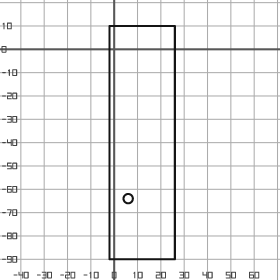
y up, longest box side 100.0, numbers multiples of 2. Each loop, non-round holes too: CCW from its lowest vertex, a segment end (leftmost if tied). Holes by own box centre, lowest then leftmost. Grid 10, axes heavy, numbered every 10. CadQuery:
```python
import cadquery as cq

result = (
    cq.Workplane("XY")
    .moveTo(-2.0, -90.0)
    .lineTo(26.0, -90.0)
    .lineTo(26.0, 10.0)
    .lineTo(-2.0, 10.0)
    .close()
    .moveTo(6.0, -64.0)
    .circle(2.0)
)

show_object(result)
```